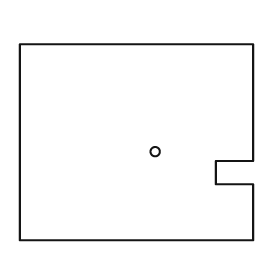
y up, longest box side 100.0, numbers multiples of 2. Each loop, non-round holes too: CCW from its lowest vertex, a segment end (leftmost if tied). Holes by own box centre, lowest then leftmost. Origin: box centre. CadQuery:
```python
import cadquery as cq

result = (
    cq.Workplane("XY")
    .moveTo(-50.0, -42.0)
    .lineTo(50.0, -42.0)
    .lineTo(50.0, -18.0)
    .lineTo(34.0, -18.0)
    .lineTo(34.0, -8.0)
    .lineTo(50.0, -8.0)
    .lineTo(50.0, 42.0)
    .lineTo(-50.0, 42.0)
    .close()
    .moveTo(8.0, -4.0)
    .circle(2.0)
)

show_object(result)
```